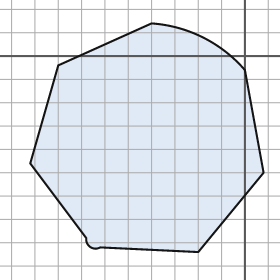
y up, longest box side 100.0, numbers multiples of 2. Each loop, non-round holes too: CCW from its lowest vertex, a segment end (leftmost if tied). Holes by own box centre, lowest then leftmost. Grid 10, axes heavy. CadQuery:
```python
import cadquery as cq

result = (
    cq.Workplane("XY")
    .moveTo(-20.0, -84.0)
    .lineTo(8.0, -50.0)
    .lineTo(0.0, -6.0)
    .threePointArc((-18.0, 8.0), (-40.0, 14.0))
    .lineTo(-80.0, -4.0)
    .lineTo(-92.0, -46.0)
    .lineTo(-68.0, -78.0)
    .threePointArc((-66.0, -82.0), (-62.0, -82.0))
    .close()
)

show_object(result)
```